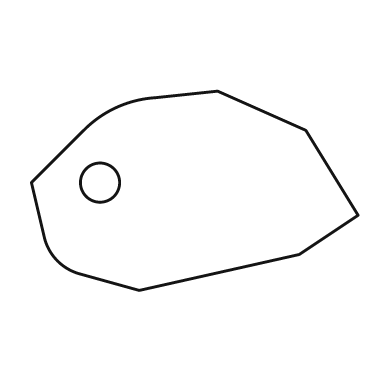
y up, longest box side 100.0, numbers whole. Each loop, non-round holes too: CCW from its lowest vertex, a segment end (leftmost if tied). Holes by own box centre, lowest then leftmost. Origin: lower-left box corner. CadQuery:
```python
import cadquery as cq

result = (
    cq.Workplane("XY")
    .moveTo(33.0, 0.0)
    .lineTo(82.0, 11.0)
    .lineTo(100.0, 23.0)
    .lineTo(84.0, 49.0)
    .lineTo(57.0, 61.0)
    .lineTo(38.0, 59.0)
    .threePointArc((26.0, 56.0), (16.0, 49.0))
    .lineTo(0.0, 33.0)
    .lineTo(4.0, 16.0)
    .threePointArc((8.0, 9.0), (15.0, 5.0))
    .close()
    .moveTo(21.0, 33.0)
    .circle(6.0)
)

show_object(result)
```